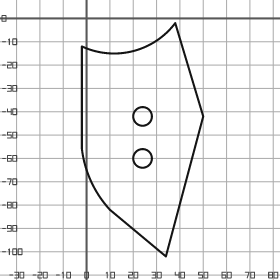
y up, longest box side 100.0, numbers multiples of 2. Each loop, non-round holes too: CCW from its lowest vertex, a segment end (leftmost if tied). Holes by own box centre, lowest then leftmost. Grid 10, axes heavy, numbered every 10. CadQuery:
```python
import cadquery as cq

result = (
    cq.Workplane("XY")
    .moveTo(34.0, -102.0)
    .lineTo(50.0, -42.0)
    .lineTo(38.0, -2.0)
    .threePointArc((20.0, -14.0), (-2.0, -12.0))
    .lineTo(-2.0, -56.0)
    .threePointArc((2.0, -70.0), (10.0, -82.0))
    .close()
    .moveTo(24.0, -60.0)
    .circle(4.0)
    .moveTo(24.0, -42.0)
    .circle(4.0)
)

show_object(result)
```